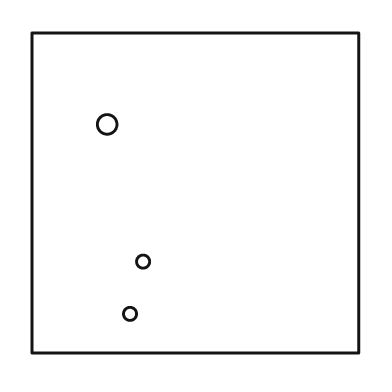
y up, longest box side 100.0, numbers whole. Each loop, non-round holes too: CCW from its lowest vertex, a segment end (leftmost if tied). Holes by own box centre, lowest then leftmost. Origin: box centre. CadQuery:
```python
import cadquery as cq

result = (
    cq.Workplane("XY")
    .moveTo(-50.0, -49.0)
    .lineTo(50.0, -49.0)
    .lineTo(50.0, 49.0)
    .lineTo(-50.0, 49.0)
    .close()
    .moveTo(-20.0, -37.0)
    .circle(2.0)
    .moveTo(-16.0, -21.0)
    .circle(2.0)
    .moveTo(-27.0, 21.0)
    .circle(3.0)
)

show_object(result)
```